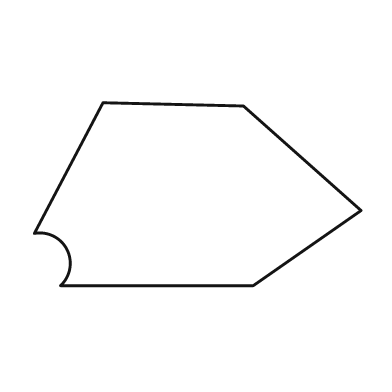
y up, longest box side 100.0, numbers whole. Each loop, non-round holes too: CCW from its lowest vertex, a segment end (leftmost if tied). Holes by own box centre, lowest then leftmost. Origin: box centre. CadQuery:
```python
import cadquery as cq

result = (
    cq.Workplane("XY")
    .moveTo(-42.0, -28.0)
    .lineTo(17.0, -28.0)
    .lineTo(50.0, -5.0)
    .lineTo(14.0, 27.0)
    .lineTo(-29.0, 28.0)
    .lineTo(-50.0, -12.0)
    .threePointArc((-40.0, -17.0), (-42.0, -28.0))
    .close()
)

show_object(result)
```